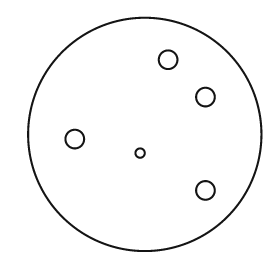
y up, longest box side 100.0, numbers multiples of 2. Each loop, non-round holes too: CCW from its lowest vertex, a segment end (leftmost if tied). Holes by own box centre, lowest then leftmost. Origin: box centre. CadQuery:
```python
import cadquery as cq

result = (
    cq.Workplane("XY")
    .moveTo(0.0, 0.0)
    .circle(50.0)
    .moveTo(26.0, -24.0)
    .circle(4.0)
    .moveTo(-2.0, -8.0)
    .circle(2.0)
    .moveTo(-30.0, -2.0)
    .circle(4.0)
    .moveTo(26.0, 16.0)
    .circle(4.0)
    .moveTo(10.0, 32.0)
    .circle(4.0)
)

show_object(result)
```